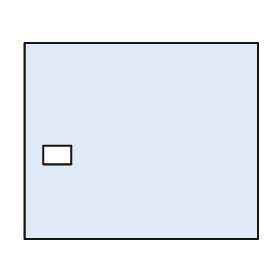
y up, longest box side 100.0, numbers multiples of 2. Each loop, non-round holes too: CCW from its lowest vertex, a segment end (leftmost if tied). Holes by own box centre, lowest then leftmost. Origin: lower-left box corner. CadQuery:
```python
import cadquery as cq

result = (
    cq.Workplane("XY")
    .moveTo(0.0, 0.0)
    .lineTo(100.0, 0.0)
    .lineTo(100.0, 84.0)
    .lineTo(0.0, 84.0)
    .close()
    .moveTo(8.0, 32.0)
    .lineTo(20.0, 32.0)
    .lineTo(20.0, 40.0)
    .lineTo(8.0, 40.0)
    .close()
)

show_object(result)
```